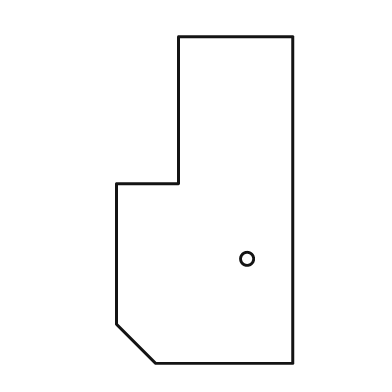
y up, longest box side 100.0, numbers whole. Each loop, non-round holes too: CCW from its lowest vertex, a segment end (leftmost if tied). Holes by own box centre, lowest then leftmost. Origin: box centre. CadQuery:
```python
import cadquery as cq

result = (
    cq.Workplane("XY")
    .moveTo(-15.0, -50.0)
    .lineTo(27.0, -50.0)
    .lineTo(27.0, 50.0)
    .lineTo(-8.0, 50.0)
    .lineTo(-8.0, 5.0)
    .lineTo(-27.0, 5.0)
    .lineTo(-27.0, -38.0)
    .close()
    .moveTo(13.0, -18.0)
    .circle(2.0)
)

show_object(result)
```